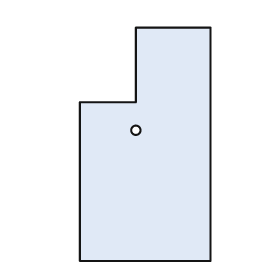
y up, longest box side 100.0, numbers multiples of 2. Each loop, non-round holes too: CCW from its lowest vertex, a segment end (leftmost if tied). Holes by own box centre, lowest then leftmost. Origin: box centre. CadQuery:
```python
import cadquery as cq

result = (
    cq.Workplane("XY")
    .moveTo(-28.0, -50.0)
    .lineTo(28.0, -50.0)
    .lineTo(28.0, 50.0)
    .lineTo(-4.0, 50.0)
    .lineTo(-4.0, 18.0)
    .lineTo(-28.0, 18.0)
    .close()
    .moveTo(-4.0, 6.0)
    .circle(2.0)
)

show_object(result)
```